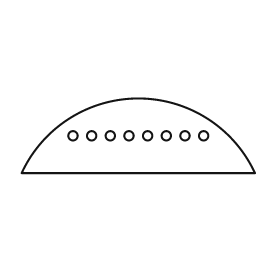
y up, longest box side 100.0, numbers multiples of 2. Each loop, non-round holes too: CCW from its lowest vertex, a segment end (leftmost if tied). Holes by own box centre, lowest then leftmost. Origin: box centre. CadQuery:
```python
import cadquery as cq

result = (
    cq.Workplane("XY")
    .moveTo(-50.0, -16.0)
    .lineTo(50.0, -16.0)
    .threePointArc((0.0, 16.0), (-50.0, -16.0))
    .close()
    .moveTo(-28.0, 0.0)
    .circle(2.0)
    .moveTo(-20.0, 0.0)
    .circle(2.0)
    .moveTo(-12.0, 0.0)
    .circle(2.0)
    .moveTo(-4.0, 0.0)
    .circle(2.0)
    .moveTo(4.0, 0.0)
    .circle(2.0)
    .moveTo(12.0, 0.0)
    .circle(2.0)
    .moveTo(20.0, 0.0)
    .circle(2.0)
    .moveTo(28.0, 0.0)
    .circle(2.0)
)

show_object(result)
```